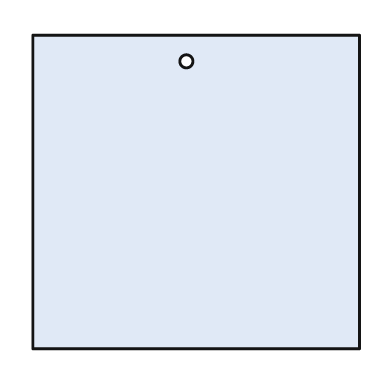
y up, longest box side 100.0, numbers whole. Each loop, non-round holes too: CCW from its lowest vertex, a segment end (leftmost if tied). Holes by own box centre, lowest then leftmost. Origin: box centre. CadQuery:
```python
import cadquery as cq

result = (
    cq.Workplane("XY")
    .moveTo(-50.0, -48.0)
    .lineTo(50.0, -48.0)
    .lineTo(50.0, 48.0)
    .lineTo(-50.0, 48.0)
    .close()
    .moveTo(-3.0, 40.0)
    .circle(2.0)
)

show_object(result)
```